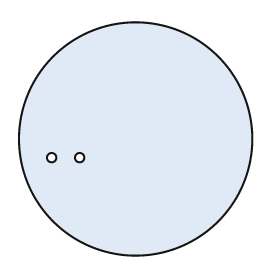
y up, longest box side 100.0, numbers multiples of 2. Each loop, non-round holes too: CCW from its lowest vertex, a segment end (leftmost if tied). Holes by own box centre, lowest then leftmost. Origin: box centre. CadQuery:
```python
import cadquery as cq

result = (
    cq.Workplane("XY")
    .moveTo(0.0, 0.0)
    .circle(50.0)
    .moveTo(-36.0, -8.0)
    .circle(2.0)
    .moveTo(-24.0, -8.0)
    .circle(2.0)
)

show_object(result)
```